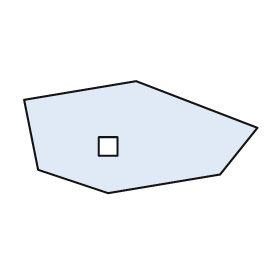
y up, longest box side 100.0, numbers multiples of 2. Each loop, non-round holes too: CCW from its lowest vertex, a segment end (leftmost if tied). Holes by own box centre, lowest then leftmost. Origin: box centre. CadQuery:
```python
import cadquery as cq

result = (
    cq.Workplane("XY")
    .moveTo(-14.0, -24.0)
    .lineTo(34.0, -16.0)
    .lineTo(50.0, 4.0)
    .lineTo(-2.0, 24.0)
    .lineTo(-50.0, 16.0)
    .lineTo(-44.0, -14.0)
    .close()
    .moveTo(-18.0, -8.0)
    .lineTo(-10.0, -8.0)
    .lineTo(-10.0, 0.0)
    .lineTo(-18.0, 0.0)
    .close()
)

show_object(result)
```